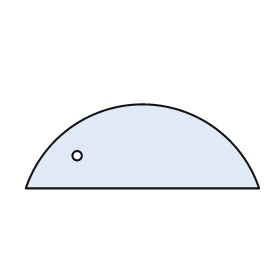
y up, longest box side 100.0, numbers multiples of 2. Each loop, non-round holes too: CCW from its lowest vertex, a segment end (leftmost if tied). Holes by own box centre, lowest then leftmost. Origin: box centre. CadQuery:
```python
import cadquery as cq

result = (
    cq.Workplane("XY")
    .moveTo(-50.0, -18.0)
    .lineTo(50.0, -18.0)
    .threePointArc((0.0, 18.0), (-50.0, -18.0))
    .close()
    .moveTo(-28.0, -4.0)
    .circle(2.0)
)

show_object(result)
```